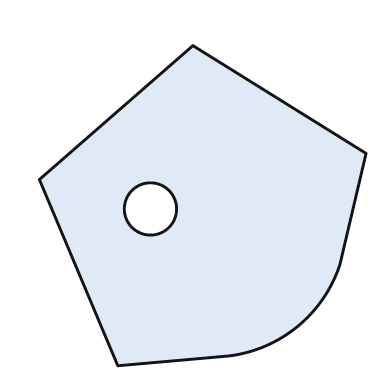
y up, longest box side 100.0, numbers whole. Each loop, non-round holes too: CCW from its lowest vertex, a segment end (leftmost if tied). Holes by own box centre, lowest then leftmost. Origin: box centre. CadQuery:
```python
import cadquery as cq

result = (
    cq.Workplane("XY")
    .moveTo(-26.0, -49.0)
    .lineTo(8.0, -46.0)
    .threePointArc((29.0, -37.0), (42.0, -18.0))
    .lineTo(50.0, 16.0)
    .lineTo(-3.0, 49.0)
    .lineTo(-50.0, 8.0)
    .close()
    .moveTo(-16.0, -1.0)
    .circle(8.0)
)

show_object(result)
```